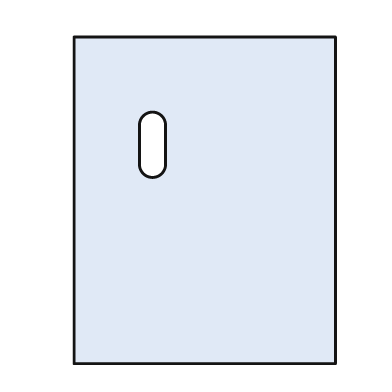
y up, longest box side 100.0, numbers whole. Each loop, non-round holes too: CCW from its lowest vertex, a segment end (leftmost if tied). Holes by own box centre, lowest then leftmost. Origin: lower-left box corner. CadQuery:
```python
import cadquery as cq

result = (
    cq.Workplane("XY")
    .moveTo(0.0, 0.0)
    .lineTo(80.0, 0.0)
    .lineTo(80.0, 100.0)
    .lineTo(0.0, 100.0)
    .close()
    .moveTo(20.0, 61.0)
    .threePointArc((24.0, 57.0), (28.0, 61.0))
    .lineTo(28.0, 73.0)
    .threePointArc((24.0, 77.0), (20.0, 73.0))
    .close()
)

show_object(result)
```